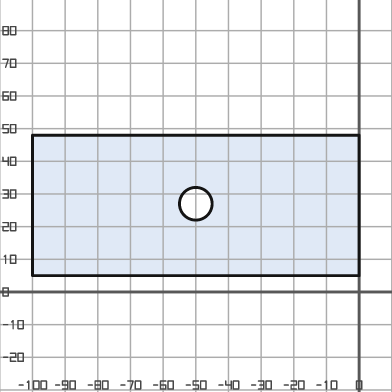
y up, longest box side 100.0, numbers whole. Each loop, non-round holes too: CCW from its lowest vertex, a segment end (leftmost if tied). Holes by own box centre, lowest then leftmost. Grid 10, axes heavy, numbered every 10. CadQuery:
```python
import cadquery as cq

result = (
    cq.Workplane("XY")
    .moveTo(-100.0, 5.0)
    .lineTo(0.0, 5.0)
    .lineTo(0.0, 48.0)
    .lineTo(-100.0, 48.0)
    .close()
    .moveTo(-50.0, 27.0)
    .circle(5.0)
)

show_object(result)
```